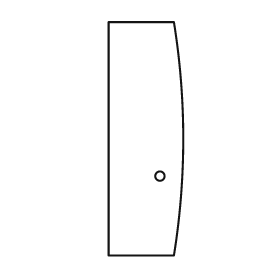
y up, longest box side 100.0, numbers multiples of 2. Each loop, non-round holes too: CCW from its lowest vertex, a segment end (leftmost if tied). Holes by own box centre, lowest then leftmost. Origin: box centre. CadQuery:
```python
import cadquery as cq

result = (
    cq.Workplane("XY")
    .moveTo(-16.0, -50.0)
    .lineTo(12.0, -50.0)
    .threePointArc((16.0, 0.0), (12.0, 50.0))
    .lineTo(-16.0, 50.0)
    .close()
    .moveTo(6.0, -16.0)
    .circle(2.0)
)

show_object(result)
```